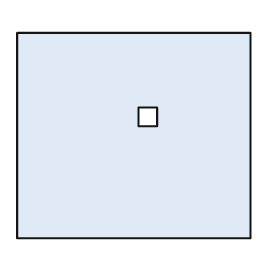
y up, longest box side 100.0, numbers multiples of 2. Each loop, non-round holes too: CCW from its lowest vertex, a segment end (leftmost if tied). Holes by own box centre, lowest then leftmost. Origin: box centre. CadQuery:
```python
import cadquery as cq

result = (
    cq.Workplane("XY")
    .moveTo(-50.0, -44.0)
    .lineTo(50.0, -44.0)
    .lineTo(50.0, 44.0)
    .lineTo(-50.0, 44.0)
    .close()
    .moveTo(2.0, 4.0)
    .lineTo(10.0, 4.0)
    .lineTo(10.0, 12.0)
    .lineTo(2.0, 12.0)
    .close()
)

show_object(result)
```